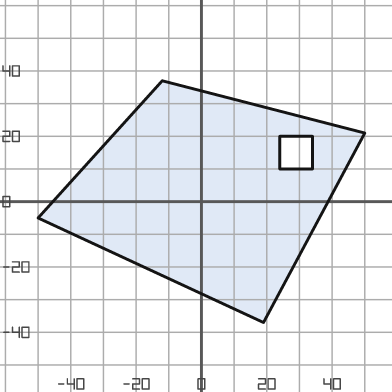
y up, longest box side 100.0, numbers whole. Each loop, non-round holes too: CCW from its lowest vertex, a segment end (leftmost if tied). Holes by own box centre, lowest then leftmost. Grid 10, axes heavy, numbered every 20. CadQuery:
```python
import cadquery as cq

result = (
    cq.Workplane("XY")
    .moveTo(19.0, -37.0)
    .lineTo(50.0, 21.0)
    .lineTo(-12.0, 37.0)
    .lineTo(-50.0, -5.0)
    .close()
    .moveTo(24.0, 10.0)
    .lineTo(34.0, 10.0)
    .lineTo(34.0, 20.0)
    .lineTo(24.0, 20.0)
    .close()
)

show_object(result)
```